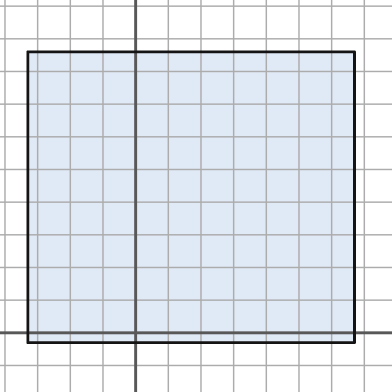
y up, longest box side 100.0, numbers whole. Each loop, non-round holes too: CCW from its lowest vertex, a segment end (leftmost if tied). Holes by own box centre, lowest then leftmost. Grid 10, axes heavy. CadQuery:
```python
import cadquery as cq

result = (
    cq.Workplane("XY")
    .moveTo(-33.0, -3.0)
    .lineTo(67.0, -3.0)
    .lineTo(67.0, 86.0)
    .lineTo(-33.0, 86.0)
    .close()
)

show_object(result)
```